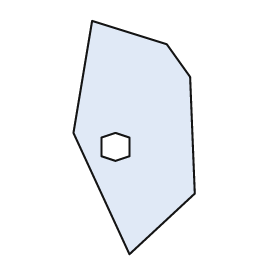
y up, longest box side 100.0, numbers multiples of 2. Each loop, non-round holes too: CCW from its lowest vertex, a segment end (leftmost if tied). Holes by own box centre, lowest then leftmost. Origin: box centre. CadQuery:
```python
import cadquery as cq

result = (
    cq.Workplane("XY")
    .moveTo(-2.0, -50.0)
    .lineTo(26.0, -24.0)
    .lineTo(24.0, 26.0)
    .lineTo(14.0, 40.0)
    .lineTo(-18.0, 50.0)
    .lineTo(-26.0, 2.0)
    .close()
    .moveTo(-8.0, -10.0)
    .lineTo(-2.0, -8.0)
    .lineTo(-2.0, 0.0)
    .lineTo(-8.0, 2.0)
    .lineTo(-14.0, 0.0)
    .lineTo(-14.0, -8.0)
    .close()
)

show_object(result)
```